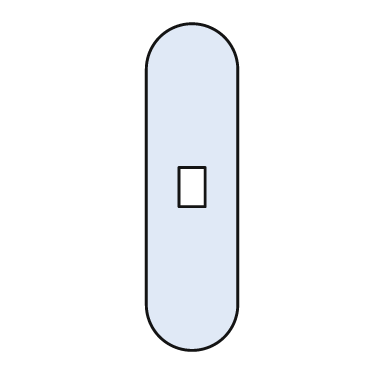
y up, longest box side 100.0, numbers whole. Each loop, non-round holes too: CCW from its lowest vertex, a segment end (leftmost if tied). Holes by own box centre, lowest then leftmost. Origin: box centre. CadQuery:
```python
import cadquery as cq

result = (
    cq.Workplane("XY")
    .moveTo(-14.0, -36.0)
    .threePointArc((0.0, -50.0), (14.0, -36.0))
    .lineTo(14.0, 36.0)
    .threePointArc((0.0, 50.0), (-14.0, 36.0))
    .close()
    .moveTo(-4.0, -6.0)
    .lineTo(4.0, -6.0)
    .lineTo(4.0, 6.0)
    .lineTo(-4.0, 6.0)
    .close()
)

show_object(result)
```